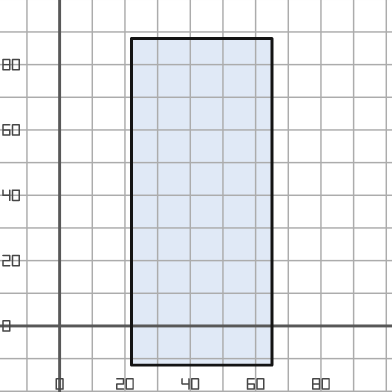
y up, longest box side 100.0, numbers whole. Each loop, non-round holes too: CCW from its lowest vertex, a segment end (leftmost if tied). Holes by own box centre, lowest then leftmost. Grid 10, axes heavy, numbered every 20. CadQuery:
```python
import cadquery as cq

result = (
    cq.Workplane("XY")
    .moveTo(22.0, -12.0)
    .lineTo(65.0, -12.0)
    .lineTo(65.0, 88.0)
    .lineTo(22.0, 88.0)
    .close()
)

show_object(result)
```